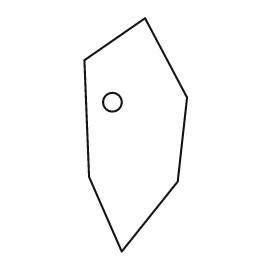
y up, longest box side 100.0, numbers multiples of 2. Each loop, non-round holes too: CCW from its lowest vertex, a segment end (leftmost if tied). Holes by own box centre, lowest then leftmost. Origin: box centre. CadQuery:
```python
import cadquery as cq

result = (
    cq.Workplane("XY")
    .moveTo(-6.0, -50.0)
    .lineTo(18.0, -20.0)
    .lineTo(22.0, 16.0)
    .lineTo(4.0, 50.0)
    .lineTo(-22.0, 32.0)
    .lineTo(-20.0, -18.0)
    .close()
    .moveTo(-10.0, 14.0)
    .circle(4.0)
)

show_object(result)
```